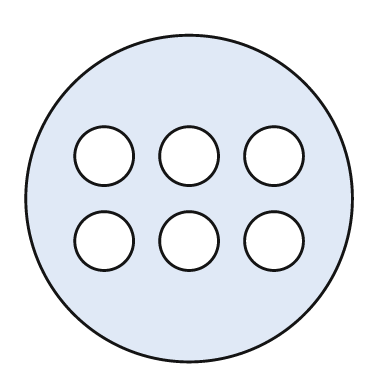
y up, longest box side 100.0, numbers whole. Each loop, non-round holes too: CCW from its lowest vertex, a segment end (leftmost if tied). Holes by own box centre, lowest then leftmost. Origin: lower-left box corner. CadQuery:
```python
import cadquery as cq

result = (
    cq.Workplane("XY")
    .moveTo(50.0, 50.0)
    .circle(50.0)
    .moveTo(24.0, 37.0)
    .circle(9.0)
    .moveTo(50.0, 37.0)
    .circle(9.0)
    .moveTo(76.0, 37.0)
    .circle(9.0)
    .moveTo(24.0, 63.0)
    .circle(9.0)
    .moveTo(50.0, 63.0)
    .circle(9.0)
    .moveTo(76.0, 63.0)
    .circle(9.0)
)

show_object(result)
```